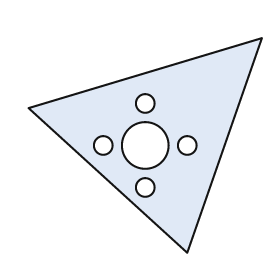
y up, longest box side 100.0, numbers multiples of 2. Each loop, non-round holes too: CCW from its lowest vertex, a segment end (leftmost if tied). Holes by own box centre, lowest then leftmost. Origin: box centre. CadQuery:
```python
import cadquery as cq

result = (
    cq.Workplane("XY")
    .moveTo(18.0, -46.0)
    .lineTo(50.0, 46.0)
    .lineTo(-50.0, 16.0)
    .close()
    .moveTo(0.0, -18.0)
    .circle(4.0)
    .moveTo(-18.0, 0.0)
    .circle(4.0)
    .moveTo(0.0, 0.0)
    .circle(10.0)
    .moveTo(18.0, 0.0)
    .circle(4.0)
    .moveTo(0.0, 18.0)
    .circle(4.0)
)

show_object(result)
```